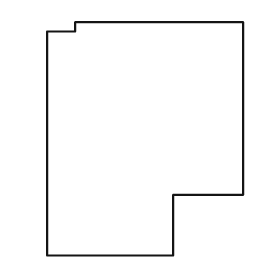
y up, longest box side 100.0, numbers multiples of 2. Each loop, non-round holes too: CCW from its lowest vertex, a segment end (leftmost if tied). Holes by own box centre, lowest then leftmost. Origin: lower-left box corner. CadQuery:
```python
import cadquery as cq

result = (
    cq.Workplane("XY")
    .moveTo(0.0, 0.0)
    .lineTo(54.0, 0.0)
    .lineTo(54.0, 26.0)
    .lineTo(84.0, 26.0)
    .lineTo(84.0, 100.0)
    .lineTo(12.0, 100.0)
    .lineTo(12.0, 96.0)
    .lineTo(0.0, 96.0)
    .close()
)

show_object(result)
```